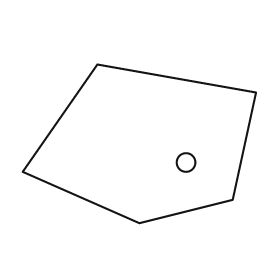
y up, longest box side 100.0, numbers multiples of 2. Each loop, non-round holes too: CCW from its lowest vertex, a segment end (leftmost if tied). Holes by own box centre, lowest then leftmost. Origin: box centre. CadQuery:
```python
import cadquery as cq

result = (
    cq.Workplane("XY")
    .moveTo(0.0, -34.0)
    .lineTo(40.0, -24.0)
    .lineTo(50.0, 22.0)
    .lineTo(-18.0, 34.0)
    .lineTo(-50.0, -12.0)
    .close()
    .moveTo(20.0, -8.0)
    .circle(4.0)
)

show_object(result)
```